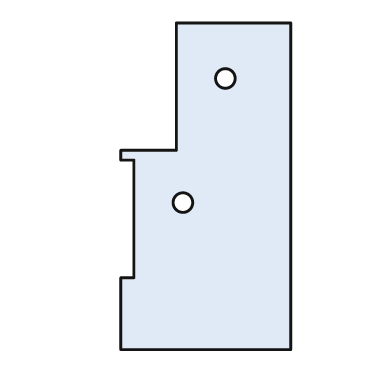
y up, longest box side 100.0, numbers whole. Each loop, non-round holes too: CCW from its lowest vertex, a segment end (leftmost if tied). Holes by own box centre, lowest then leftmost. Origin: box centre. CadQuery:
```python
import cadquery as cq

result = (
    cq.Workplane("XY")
    .moveTo(-26.0, -50.0)
    .lineTo(26.0, -50.0)
    .lineTo(26.0, 50.0)
    .lineTo(-9.0, 50.0)
    .lineTo(-9.0, 11.0)
    .lineTo(-26.0, 11.0)
    .lineTo(-26.0, 8.0)
    .lineTo(-22.0, 8.0)
    .lineTo(-22.0, -28.0)
    .lineTo(-26.0, -28.0)
    .close()
    .moveTo(-7.0, -5.0)
    .circle(3.0)
    .moveTo(6.0, 33.0)
    .circle(3.0)
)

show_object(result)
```